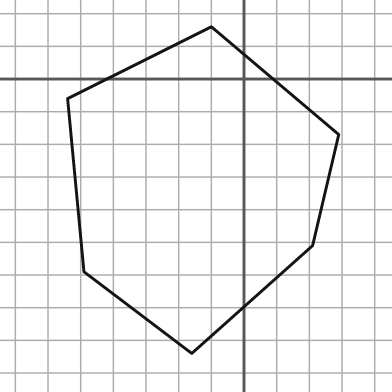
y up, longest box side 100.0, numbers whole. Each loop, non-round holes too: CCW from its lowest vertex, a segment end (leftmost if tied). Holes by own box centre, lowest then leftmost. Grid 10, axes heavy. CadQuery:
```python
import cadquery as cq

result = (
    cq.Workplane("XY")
    .moveTo(-16.0, -84.0)
    .lineTo(21.0, -51.0)
    .lineTo(29.0, -17.0)
    .lineTo(-10.0, 16.0)
    .lineTo(-54.0, -6.0)
    .lineTo(-49.0, -59.0)
    .close()
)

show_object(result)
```